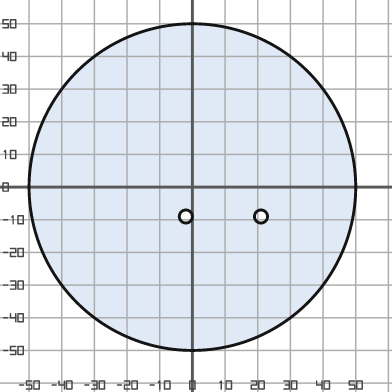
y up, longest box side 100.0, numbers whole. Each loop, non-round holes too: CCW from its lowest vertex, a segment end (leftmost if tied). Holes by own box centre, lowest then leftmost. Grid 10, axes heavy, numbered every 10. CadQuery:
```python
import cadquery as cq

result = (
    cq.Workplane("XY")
    .moveTo(0.0, 0.0)
    .circle(50.0)
    .moveTo(-2.0, -9.0)
    .circle(2.0)
    .moveTo(21.0, -9.0)
    .circle(2.0)
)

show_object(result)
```